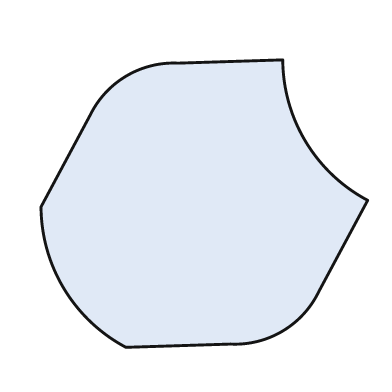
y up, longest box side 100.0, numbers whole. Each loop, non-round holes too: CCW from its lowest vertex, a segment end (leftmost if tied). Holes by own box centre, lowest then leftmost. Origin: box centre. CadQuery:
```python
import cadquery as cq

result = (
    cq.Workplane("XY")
    .moveTo(-24.0, -44.0)
    .lineTo(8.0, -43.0)
    .threePointArc((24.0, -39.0), (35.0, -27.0))
    .lineTo(50.0, 1.0)
    .threePointArc((31.0, 19.0), (24.0, 44.0))
    .lineTo(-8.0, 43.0)
    .threePointArc((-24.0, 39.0), (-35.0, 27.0))
    .lineTo(-50.0, -1.0)
    .threePointArc((-43.0, -26.0), (-24.0, -44.0))
    .close()
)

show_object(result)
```